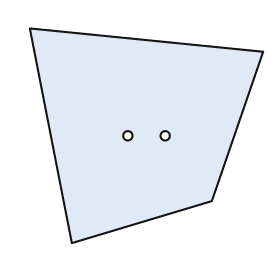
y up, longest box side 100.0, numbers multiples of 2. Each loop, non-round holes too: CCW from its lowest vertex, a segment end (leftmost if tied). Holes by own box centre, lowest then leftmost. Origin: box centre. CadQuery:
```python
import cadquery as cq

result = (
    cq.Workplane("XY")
    .moveTo(-32.0, -46.0)
    .lineTo(28.0, -28.0)
    .lineTo(50.0, 36.0)
    .lineTo(-50.0, 46.0)
    .close()
    .moveTo(-8.0, 0.0)
    .circle(2.0)
    .moveTo(8.0, 0.0)
    .circle(2.0)
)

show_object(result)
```